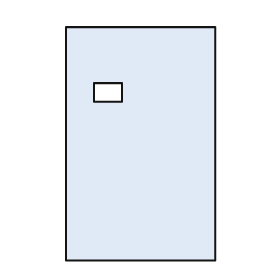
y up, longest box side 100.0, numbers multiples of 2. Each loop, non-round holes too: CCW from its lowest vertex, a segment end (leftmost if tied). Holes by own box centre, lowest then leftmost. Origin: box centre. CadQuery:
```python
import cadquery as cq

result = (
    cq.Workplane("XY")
    .moveTo(-32.0, -50.0)
    .lineTo(32.0, -50.0)
    .lineTo(32.0, 50.0)
    .lineTo(-32.0, 50.0)
    .close()
    .moveTo(-20.0, 18.0)
    .lineTo(-8.0, 18.0)
    .lineTo(-8.0, 26.0)
    .lineTo(-20.0, 26.0)
    .close()
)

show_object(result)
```